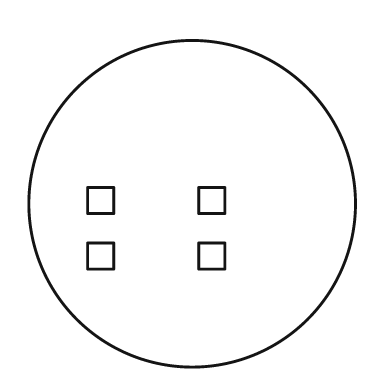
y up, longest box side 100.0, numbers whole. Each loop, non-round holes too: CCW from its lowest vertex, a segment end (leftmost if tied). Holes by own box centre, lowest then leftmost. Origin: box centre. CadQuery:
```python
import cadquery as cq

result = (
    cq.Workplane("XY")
    .moveTo(0.0, 0.0)
    .circle(50.0)
    .moveTo(-32.0, -20.0)
    .lineTo(-24.0, -20.0)
    .lineTo(-24.0, -12.0)
    .lineTo(-32.0, -12.0)
    .close()
    .moveTo(2.0, -20.0)
    .lineTo(10.0, -20.0)
    .lineTo(10.0, -12.0)
    .lineTo(2.0, -12.0)
    .close()
    .moveTo(-32.0, -3.0)
    .lineTo(-24.0, -3.0)
    .lineTo(-24.0, 5.0)
    .lineTo(-32.0, 5.0)
    .close()
    .moveTo(2.0, -3.0)
    .lineTo(10.0, -3.0)
    .lineTo(10.0, 5.0)
    .lineTo(2.0, 5.0)
    .close()
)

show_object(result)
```